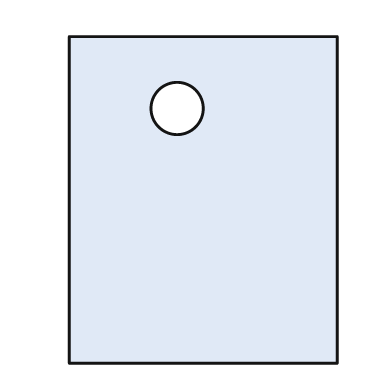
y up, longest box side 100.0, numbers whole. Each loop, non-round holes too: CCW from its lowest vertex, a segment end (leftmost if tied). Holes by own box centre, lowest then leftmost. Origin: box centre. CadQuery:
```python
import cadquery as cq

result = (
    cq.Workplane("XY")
    .moveTo(-41.0, -50.0)
    .lineTo(41.0, -50.0)
    .lineTo(41.0, 50.0)
    .lineTo(-41.0, 50.0)
    .close()
    .moveTo(-8.0, 28.0)
    .circle(8.0)
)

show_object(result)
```